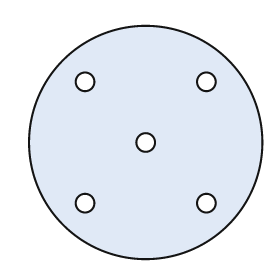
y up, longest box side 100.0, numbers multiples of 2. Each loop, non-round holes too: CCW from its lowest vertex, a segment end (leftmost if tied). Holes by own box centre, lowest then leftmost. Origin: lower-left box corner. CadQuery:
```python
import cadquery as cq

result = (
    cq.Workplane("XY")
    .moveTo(50.0, 50.0)
    .circle(50.0)
    .moveTo(24.0, 24.0)
    .circle(4.0)
    .moveTo(76.0, 24.0)
    .circle(4.0)
    .moveTo(50.0, 50.0)
    .circle(4.0)
    .moveTo(24.0, 76.0)
    .circle(4.0)
    .moveTo(76.0, 76.0)
    .circle(4.0)
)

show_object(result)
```